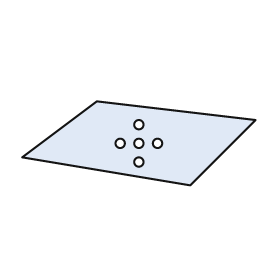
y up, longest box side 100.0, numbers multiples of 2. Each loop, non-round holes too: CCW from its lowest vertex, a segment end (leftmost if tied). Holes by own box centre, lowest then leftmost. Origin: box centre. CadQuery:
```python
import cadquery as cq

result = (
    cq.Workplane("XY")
    .moveTo(22.0, -18.0)
    .lineTo(50.0, 10.0)
    .lineTo(-18.0, 18.0)
    .lineTo(-50.0, -6.0)
    .close()
    .moveTo(0.0, -8.0)
    .circle(2.0)
    .moveTo(-8.0, 0.0)
    .circle(2.0)
    .moveTo(0.0, 0.0)
    .circle(2.0)
    .moveTo(8.0, 0.0)
    .circle(2.0)
    .moveTo(0.0, 8.0)
    .circle(2.0)
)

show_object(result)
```